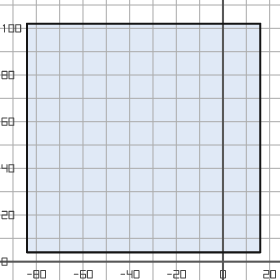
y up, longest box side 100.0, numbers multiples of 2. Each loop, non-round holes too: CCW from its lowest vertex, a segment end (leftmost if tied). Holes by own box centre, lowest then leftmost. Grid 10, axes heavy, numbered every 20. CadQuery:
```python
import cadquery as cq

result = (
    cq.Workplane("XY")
    .moveTo(-84.0, 4.0)
    .lineTo(16.0, 4.0)
    .lineTo(16.0, 102.0)
    .lineTo(-84.0, 102.0)
    .close()
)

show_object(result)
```